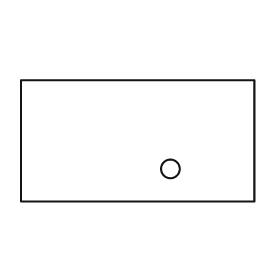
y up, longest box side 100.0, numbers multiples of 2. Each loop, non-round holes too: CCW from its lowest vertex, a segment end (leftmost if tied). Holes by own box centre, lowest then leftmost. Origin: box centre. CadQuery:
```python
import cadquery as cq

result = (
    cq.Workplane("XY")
    .moveTo(-50.0, -26.0)
    .lineTo(50.0, -26.0)
    .lineTo(50.0, 26.0)
    .lineTo(-50.0, 26.0)
    .close()
    .moveTo(14.0, -12.0)
    .circle(4.0)
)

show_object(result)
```